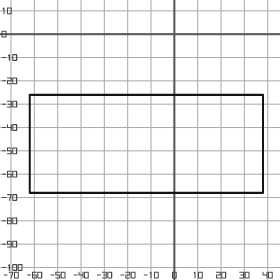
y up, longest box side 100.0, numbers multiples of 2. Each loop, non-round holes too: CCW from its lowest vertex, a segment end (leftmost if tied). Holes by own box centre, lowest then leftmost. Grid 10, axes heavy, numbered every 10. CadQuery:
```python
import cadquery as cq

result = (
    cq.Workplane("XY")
    .moveTo(-62.0, -68.0)
    .lineTo(38.0, -68.0)
    .lineTo(38.0, -26.0)
    .lineTo(-62.0, -26.0)
    .close()
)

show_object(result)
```